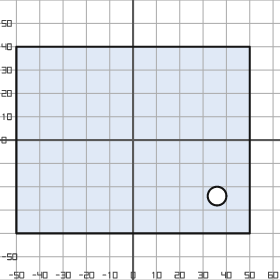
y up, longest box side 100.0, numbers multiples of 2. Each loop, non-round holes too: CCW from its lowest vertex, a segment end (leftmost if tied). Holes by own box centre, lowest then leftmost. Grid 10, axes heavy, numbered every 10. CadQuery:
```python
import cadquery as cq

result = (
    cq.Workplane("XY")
    .moveTo(-50.0, -40.0)
    .lineTo(50.0, -40.0)
    .lineTo(50.0, 40.0)
    .lineTo(-50.0, 40.0)
    .close()
    .moveTo(36.0, -24.0)
    .circle(4.0)
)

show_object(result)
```